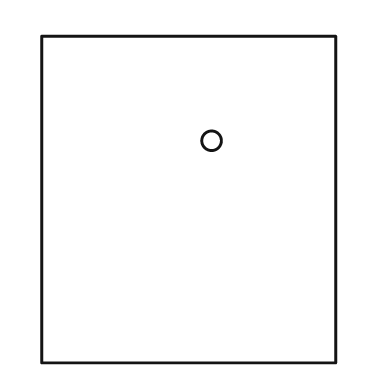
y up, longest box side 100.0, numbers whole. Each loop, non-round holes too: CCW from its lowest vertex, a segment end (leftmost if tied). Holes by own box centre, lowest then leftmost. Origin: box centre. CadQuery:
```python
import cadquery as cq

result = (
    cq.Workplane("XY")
    .moveTo(-45.0, -50.0)
    .lineTo(45.0, -50.0)
    .lineTo(45.0, 50.0)
    .lineTo(-45.0, 50.0)
    .close()
    .moveTo(7.0, 18.0)
    .circle(3.0)
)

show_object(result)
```